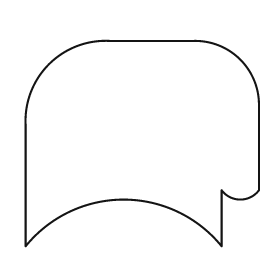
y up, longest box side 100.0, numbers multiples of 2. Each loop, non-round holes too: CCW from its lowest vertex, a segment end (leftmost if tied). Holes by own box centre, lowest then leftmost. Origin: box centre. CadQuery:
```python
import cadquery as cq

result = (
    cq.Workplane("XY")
    .moveTo(-50.0, -44.0)
    .threePointArc((-8.0, -24.0), (34.0, -44.0))
    .lineTo(34.0, -20.0)
    .threePointArc((42.0, -24.0), (50.0, -20.0))
    .lineTo(50.0, 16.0)
    .threePointArc((42.0, 36.0), (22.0, 44.0))
    .lineTo(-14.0, 44.0)
    .threePointArc((-40.0, 34.0), (-50.0, 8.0))
    .close()
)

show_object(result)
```